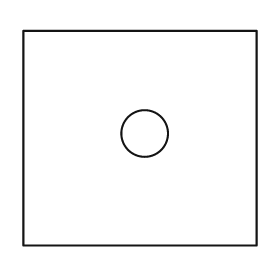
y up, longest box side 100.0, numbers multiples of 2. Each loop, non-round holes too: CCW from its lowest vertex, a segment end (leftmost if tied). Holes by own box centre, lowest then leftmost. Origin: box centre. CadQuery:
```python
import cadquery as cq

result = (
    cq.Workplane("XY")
    .moveTo(-50.0, -46.0)
    .lineTo(50.0, -46.0)
    .lineTo(50.0, 46.0)
    .lineTo(-50.0, 46.0)
    .close()
    .moveTo(2.0, 2.0)
    .circle(10.0)
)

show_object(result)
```